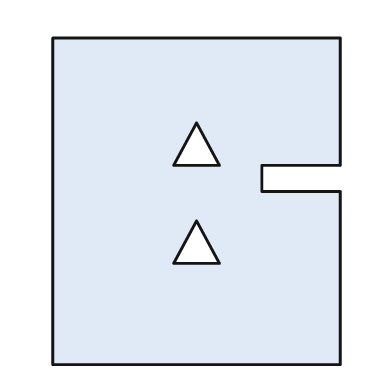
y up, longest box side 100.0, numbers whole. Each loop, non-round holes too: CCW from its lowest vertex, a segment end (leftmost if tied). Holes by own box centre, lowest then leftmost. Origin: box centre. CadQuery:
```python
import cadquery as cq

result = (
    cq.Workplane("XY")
    .moveTo(-44.0, -50.0)
    .lineTo(44.0, -50.0)
    .lineTo(44.0, 3.0)
    .lineTo(20.0, 3.0)
    .lineTo(20.0, 11.0)
    .lineTo(44.0, 11.0)
    .lineTo(44.0, 50.0)
    .lineTo(-44.0, 50.0)
    .close()
    .moveTo(-7.0, -19.0)
    .lineTo(7.0, -19.0)
    .lineTo(0.0, -6.0)
    .close()
    .moveTo(-7.0, 11.0)
    .lineTo(7.0, 11.0)
    .lineTo(0.0, 24.0)
    .close()
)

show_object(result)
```